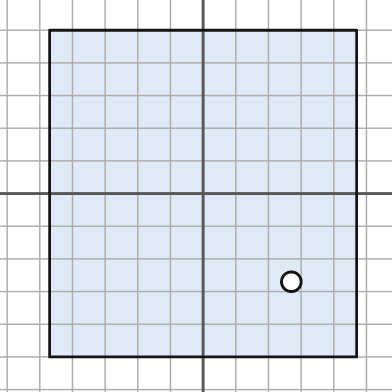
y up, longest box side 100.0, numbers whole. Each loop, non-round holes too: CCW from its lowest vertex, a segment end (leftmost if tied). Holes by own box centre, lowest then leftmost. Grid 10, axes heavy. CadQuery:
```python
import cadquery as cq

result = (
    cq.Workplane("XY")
    .moveTo(-47.0, -50.0)
    .lineTo(47.0, -50.0)
    .lineTo(47.0, 50.0)
    .lineTo(-47.0, 50.0)
    .close()
    .moveTo(27.0, -27.0)
    .circle(3.0)
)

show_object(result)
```